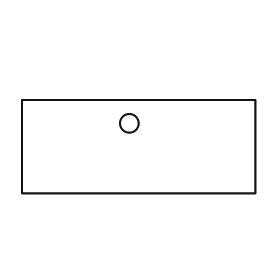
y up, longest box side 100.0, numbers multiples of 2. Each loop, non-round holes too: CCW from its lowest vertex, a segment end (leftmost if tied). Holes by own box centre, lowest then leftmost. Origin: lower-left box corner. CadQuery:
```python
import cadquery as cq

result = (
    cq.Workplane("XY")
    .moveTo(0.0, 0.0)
    .lineTo(100.0, 0.0)
    .lineTo(100.0, 40.0)
    .lineTo(0.0, 40.0)
    .close()
    .moveTo(46.0, 30.0)
    .circle(4.0)
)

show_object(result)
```